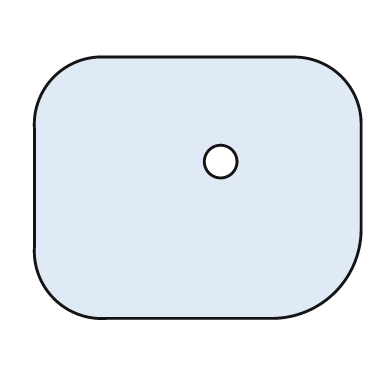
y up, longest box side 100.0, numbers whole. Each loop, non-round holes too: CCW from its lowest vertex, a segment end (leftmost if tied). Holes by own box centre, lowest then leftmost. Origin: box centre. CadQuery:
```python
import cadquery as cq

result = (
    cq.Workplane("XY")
    .moveTo(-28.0, -40.0)
    .lineTo(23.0, -40.0)
    .threePointArc((42.0, -32.0), (50.0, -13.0))
    .lineTo(50.0, 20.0)
    .threePointArc((44.0, 34.0), (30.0, 40.0))
    .lineTo(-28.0, 40.0)
    .threePointArc((-44.0, 34.0), (-50.0, 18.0))
    .lineTo(-50.0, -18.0)
    .threePointArc((-44.0, -34.0), (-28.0, -40.0))
    .close()
    .moveTo(7.0, 8.0)
    .circle(5.0)
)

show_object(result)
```